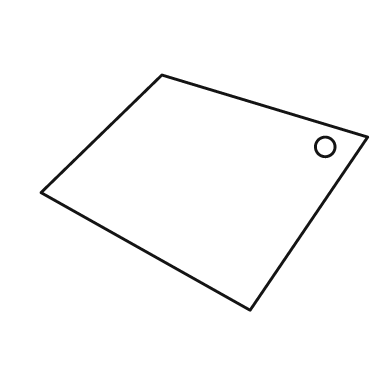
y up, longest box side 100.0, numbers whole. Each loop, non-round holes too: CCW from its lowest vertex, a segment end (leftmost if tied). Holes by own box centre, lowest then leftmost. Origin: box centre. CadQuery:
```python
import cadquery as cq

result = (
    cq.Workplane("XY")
    .moveTo(14.0, -36.0)
    .lineTo(50.0, 17.0)
    .lineTo(-13.0, 36.0)
    .lineTo(-50.0, 0.0)
    .close()
    .moveTo(37.0, 14.0)
    .circle(3.0)
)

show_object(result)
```